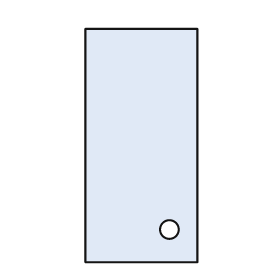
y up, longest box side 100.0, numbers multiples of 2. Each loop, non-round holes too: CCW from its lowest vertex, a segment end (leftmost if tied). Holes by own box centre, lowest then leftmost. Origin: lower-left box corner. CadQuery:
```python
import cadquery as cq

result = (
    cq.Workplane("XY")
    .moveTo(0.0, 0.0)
    .lineTo(48.0, 0.0)
    .lineTo(48.0, 100.0)
    .lineTo(0.0, 100.0)
    .close()
    .moveTo(36.0, 14.0)
    .circle(4.0)
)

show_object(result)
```